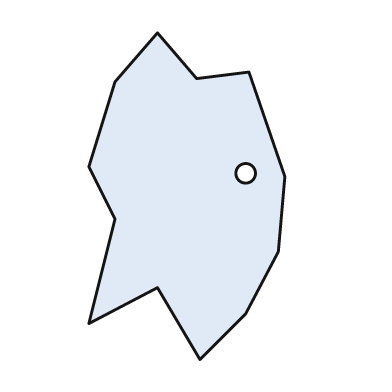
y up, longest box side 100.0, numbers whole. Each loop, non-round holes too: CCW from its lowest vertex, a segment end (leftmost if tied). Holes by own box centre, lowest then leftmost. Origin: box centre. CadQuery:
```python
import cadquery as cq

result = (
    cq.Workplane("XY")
    .moveTo(4.0, -50.0)
    .lineTo(18.0, -36.0)
    .lineTo(28.0, -17.0)
    .lineTo(30.0, 6.0)
    .lineTo(19.0, 38.0)
    .lineTo(3.0, 36.0)
    .lineTo(-9.0, 50.0)
    .lineTo(-22.0, 35.0)
    .lineTo(-30.0, 9.0)
    .lineTo(-22.0, -7.0)
    .lineTo(-30.0, -39.0)
    .lineTo(-9.0, -28.0)
    .close()
    .moveTo(18.0, 7.0)
    .circle(3.0)
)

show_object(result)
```